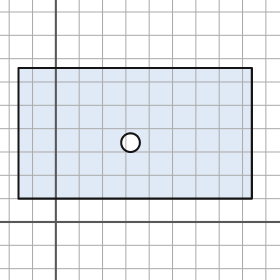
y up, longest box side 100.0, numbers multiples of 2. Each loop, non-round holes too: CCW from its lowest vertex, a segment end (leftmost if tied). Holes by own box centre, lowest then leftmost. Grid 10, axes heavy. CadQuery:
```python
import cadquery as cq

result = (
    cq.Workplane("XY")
    .moveTo(-16.0, 10.0)
    .lineTo(84.0, 10.0)
    .lineTo(84.0, 66.0)
    .lineTo(-16.0, 66.0)
    .close()
    .moveTo(32.0, 34.0)
    .circle(4.0)
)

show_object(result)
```